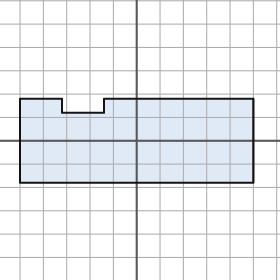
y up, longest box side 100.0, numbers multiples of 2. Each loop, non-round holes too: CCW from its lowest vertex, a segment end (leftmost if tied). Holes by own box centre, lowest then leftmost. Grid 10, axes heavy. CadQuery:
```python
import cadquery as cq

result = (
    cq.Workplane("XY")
    .moveTo(-50.0, -18.0)
    .lineTo(50.0, -18.0)
    .lineTo(50.0, 18.0)
    .lineTo(-14.0, 18.0)
    .lineTo(-14.0, 12.0)
    .lineTo(-32.0, 12.0)
    .lineTo(-32.0, 18.0)
    .lineTo(-50.0, 18.0)
    .close()
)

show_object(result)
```